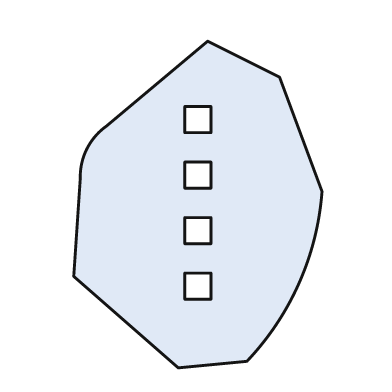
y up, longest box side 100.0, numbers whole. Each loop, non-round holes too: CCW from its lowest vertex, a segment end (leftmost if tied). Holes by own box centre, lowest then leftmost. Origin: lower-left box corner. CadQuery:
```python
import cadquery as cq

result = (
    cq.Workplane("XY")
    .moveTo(32.0, 0.0)
    .lineTo(53.0, 2.0)
    .threePointArc((69.0, 26.0), (76.0, 54.0))
    .lineTo(63.0, 89.0)
    .lineTo(41.0, 100.0)
    .lineTo(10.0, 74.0)
    .threePointArc((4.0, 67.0), (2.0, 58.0))
    .lineTo(0.0, 28.0)
    .close()
    .moveTo(34.0, 21.0)
    .lineTo(42.0, 21.0)
    .lineTo(42.0, 29.0)
    .lineTo(34.0, 29.0)
    .close()
    .moveTo(34.0, 38.0)
    .lineTo(42.0, 38.0)
    .lineTo(42.0, 46.0)
    .lineTo(34.0, 46.0)
    .close()
    .moveTo(34.0, 55.0)
    .lineTo(42.0, 55.0)
    .lineTo(42.0, 63.0)
    .lineTo(34.0, 63.0)
    .close()
    .moveTo(34.0, 72.0)
    .lineTo(42.0, 72.0)
    .lineTo(42.0, 80.0)
    .lineTo(34.0, 80.0)
    .close()
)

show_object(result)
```